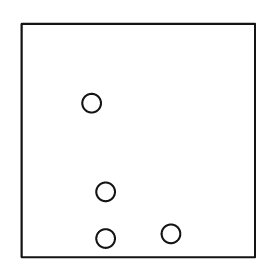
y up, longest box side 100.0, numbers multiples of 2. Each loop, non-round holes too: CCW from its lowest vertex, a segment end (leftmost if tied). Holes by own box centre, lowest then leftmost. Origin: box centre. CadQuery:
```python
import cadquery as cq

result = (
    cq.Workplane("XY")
    .moveTo(-50.0, -50.0)
    .lineTo(50.0, -50.0)
    .lineTo(50.0, 50.0)
    .lineTo(-50.0, 50.0)
    .close()
    .moveTo(-14.0, -42.0)
    .circle(4.0)
    .moveTo(14.0, -40.0)
    .circle(4.0)
    .moveTo(-14.0, -22.0)
    .circle(4.0)
    .moveTo(-20.0, 16.0)
    .circle(4.0)
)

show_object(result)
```